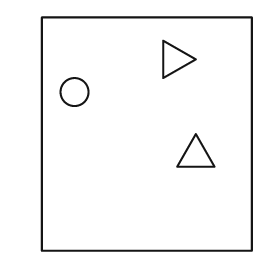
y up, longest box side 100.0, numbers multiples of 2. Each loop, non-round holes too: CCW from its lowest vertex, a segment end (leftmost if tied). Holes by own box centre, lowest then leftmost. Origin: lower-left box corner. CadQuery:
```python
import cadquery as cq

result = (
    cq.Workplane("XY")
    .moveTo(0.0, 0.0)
    .lineTo(90.0, 0.0)
    .lineTo(90.0, 100.0)
    .lineTo(0.0, 100.0)
    .close()
    .moveTo(58.0, 36.0)
    .lineTo(74.0, 36.0)
    .lineTo(66.0, 50.0)
    .close()
    .moveTo(14.0, 68.0)
    .circle(6.0)
    .moveTo(52.0, 74.0)
    .lineTo(66.0, 82.0)
    .lineTo(52.0, 90.0)
    .close()
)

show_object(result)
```